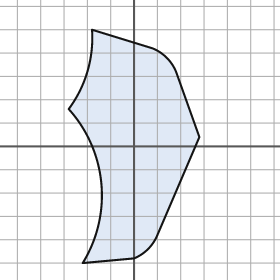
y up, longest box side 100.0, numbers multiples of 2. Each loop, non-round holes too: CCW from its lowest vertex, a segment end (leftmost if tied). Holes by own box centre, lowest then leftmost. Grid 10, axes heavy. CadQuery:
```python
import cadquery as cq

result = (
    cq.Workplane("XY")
    .moveTo(-22.0, -50.0)
    .lineTo(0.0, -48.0)
    .threePointArc((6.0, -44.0), (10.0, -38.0))
    .lineTo(28.0, 4.0)
    .lineTo(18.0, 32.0)
    .threePointArc((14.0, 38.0), (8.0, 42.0))
    .lineTo(-18.0, 50.0)
    .threePointArc((-20.0, 32.0), (-28.0, 16.0))
    .threePointArc((-14.0, -16.0), (-22.0, -50.0))
    .close()
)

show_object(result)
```